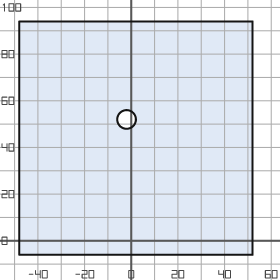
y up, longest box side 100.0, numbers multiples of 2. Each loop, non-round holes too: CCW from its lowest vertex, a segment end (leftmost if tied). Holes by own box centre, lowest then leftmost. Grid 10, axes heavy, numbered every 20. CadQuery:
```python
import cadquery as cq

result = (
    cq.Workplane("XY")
    .moveTo(-48.0, -6.0)
    .lineTo(52.0, -6.0)
    .lineTo(52.0, 94.0)
    .lineTo(-48.0, 94.0)
    .close()
    .moveTo(-2.0, 52.0)
    .circle(4.0)
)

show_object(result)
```